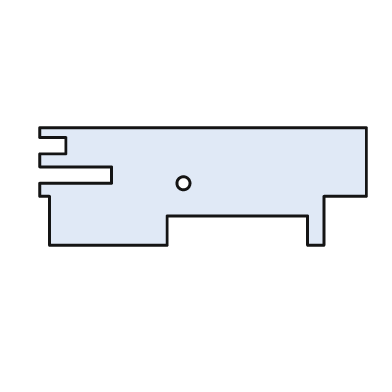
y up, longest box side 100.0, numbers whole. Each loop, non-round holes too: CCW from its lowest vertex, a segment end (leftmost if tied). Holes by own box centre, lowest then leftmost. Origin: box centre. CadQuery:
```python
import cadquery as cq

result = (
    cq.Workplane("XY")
    .moveTo(-47.0, -18.0)
    .lineTo(-11.0, -18.0)
    .lineTo(-11.0, -9.0)
    .lineTo(32.0, -9.0)
    .lineTo(32.0, -18.0)
    .lineTo(37.0, -18.0)
    .lineTo(37.0, -3.0)
    .lineTo(50.0, -3.0)
    .lineTo(50.0, 18.0)
    .lineTo(-50.0, 18.0)
    .lineTo(-50.0, 15.0)
    .lineTo(-42.0, 15.0)
    .lineTo(-42.0, 10.0)
    .lineTo(-50.0, 10.0)
    .lineTo(-50.0, 6.0)
    .lineTo(-28.0, 6.0)
    .lineTo(-28.0, 1.0)
    .lineTo(-50.0, 1.0)
    .lineTo(-50.0, -3.0)
    .lineTo(-47.0, -3.0)
    .close()
    .moveTo(-6.0, 1.0)
    .circle(2.0)
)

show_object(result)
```